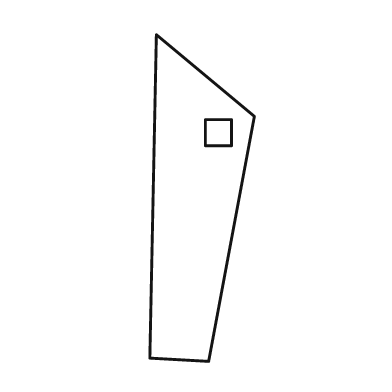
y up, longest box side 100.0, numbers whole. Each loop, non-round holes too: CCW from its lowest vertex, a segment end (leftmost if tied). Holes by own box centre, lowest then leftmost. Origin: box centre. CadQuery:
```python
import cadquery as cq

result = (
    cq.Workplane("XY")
    .moveTo(2.0, -50.0)
    .lineTo(16.0, 25.0)
    .lineTo(-14.0, 50.0)
    .lineTo(-16.0, -49.0)
    .close()
    .moveTo(1.0, 16.0)
    .lineTo(9.0, 16.0)
    .lineTo(9.0, 24.0)
    .lineTo(1.0, 24.0)
    .close()
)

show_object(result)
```